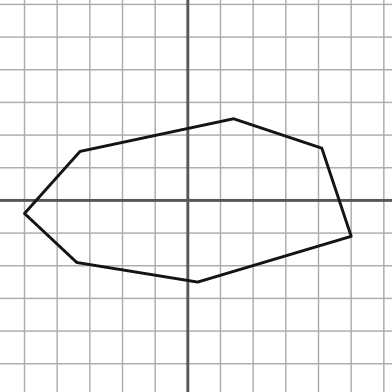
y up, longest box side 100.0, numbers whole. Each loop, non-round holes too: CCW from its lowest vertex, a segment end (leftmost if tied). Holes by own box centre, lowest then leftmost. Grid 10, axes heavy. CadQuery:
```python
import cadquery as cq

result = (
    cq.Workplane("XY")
    .moveTo(3.0, -25.0)
    .lineTo(50.0, -11.0)
    .lineTo(41.0, 16.0)
    .lineTo(14.0, 25.0)
    .lineTo(-33.0, 15.0)
    .lineTo(-50.0, -4.0)
    .lineTo(-34.0, -19.0)
    .close()
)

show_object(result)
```